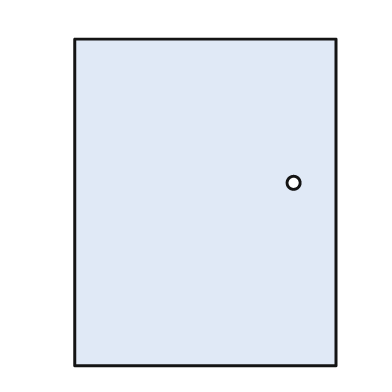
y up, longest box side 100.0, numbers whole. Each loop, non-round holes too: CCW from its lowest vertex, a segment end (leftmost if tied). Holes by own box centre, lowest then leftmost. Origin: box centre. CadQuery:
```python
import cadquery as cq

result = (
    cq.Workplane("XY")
    .moveTo(-40.0, -50.0)
    .lineTo(40.0, -50.0)
    .lineTo(40.0, 50.0)
    .lineTo(-40.0, 50.0)
    .close()
    .moveTo(27.0, 6.0)
    .circle(2.0)
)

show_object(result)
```